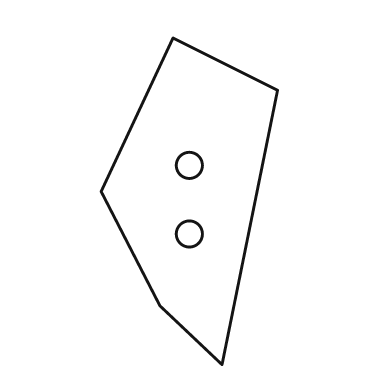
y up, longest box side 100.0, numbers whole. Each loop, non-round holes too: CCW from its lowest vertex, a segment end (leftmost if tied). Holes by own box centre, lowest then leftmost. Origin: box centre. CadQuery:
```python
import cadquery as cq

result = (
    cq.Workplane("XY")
    .moveTo(10.0, -50.0)
    .lineTo(27.0, 34.0)
    .lineTo(-5.0, 50.0)
    .lineTo(-27.0, 3.0)
    .lineTo(-9.0, -32.0)
    .close()
    .moveTo(0.0, -10.0)
    .circle(4.0)
    .moveTo(0.0, 11.0)
    .circle(4.0)
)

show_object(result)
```